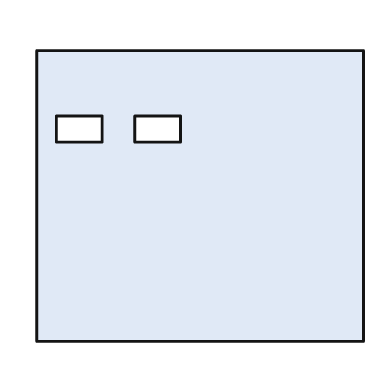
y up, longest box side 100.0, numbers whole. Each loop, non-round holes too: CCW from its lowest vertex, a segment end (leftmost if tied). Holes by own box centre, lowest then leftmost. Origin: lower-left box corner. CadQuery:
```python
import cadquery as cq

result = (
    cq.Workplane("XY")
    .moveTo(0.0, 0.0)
    .lineTo(100.0, 0.0)
    .lineTo(100.0, 89.0)
    .lineTo(0.0, 89.0)
    .close()
    .moveTo(6.0, 61.0)
    .lineTo(20.0, 61.0)
    .lineTo(20.0, 69.0)
    .lineTo(6.0, 69.0)
    .close()
    .moveTo(30.0, 61.0)
    .lineTo(44.0, 61.0)
    .lineTo(44.0, 69.0)
    .lineTo(30.0, 69.0)
    .close()
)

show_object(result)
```